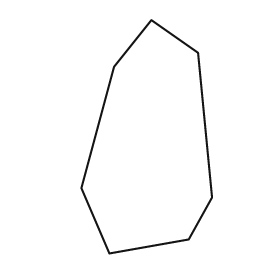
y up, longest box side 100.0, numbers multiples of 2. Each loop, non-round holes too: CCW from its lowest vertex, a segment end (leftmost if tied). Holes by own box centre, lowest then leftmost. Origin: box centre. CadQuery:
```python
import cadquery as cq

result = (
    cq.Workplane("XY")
    .moveTo(-16.0, -50.0)
    .lineTo(18.0, -44.0)
    .lineTo(28.0, -26.0)
    .lineTo(22.0, 36.0)
    .lineTo(2.0, 50.0)
    .lineTo(-14.0, 30.0)
    .lineTo(-28.0, -22.0)
    .close()
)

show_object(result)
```